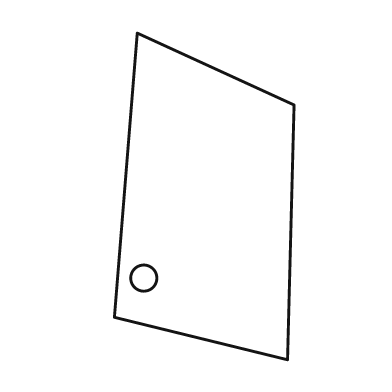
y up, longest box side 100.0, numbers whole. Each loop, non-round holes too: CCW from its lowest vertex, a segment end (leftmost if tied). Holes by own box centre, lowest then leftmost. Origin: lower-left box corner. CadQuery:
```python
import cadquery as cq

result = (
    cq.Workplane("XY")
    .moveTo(53.0, 0.0)
    .lineTo(55.0, 78.0)
    .lineTo(7.0, 100.0)
    .lineTo(0.0, 13.0)
    .close()
    .moveTo(9.0, 25.0)
    .circle(4.0)
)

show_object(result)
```